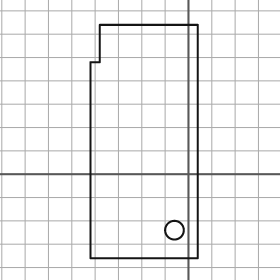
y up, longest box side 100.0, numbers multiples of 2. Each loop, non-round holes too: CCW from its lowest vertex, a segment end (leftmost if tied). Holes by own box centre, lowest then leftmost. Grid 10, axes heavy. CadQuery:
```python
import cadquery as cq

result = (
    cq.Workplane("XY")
    .moveTo(-42.0, -36.0)
    .lineTo(4.0, -36.0)
    .lineTo(4.0, 64.0)
    .lineTo(-38.0, 64.0)
    .lineTo(-38.0, 48.0)
    .lineTo(-42.0, 48.0)
    .close()
    .moveTo(-6.0, -24.0)
    .circle(4.0)
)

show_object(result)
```